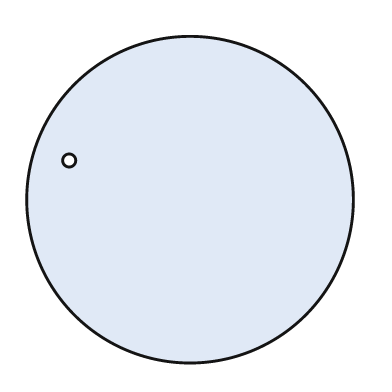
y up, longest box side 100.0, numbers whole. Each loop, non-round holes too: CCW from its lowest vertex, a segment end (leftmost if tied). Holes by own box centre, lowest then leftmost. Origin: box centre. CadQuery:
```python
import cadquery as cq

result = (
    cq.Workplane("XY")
    .moveTo(0.0, 0.0)
    .circle(50.0)
    .moveTo(-37.0, 12.0)
    .circle(2.0)
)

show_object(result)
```